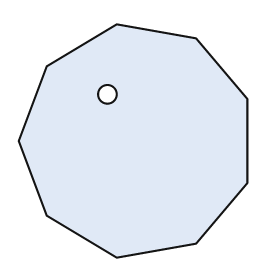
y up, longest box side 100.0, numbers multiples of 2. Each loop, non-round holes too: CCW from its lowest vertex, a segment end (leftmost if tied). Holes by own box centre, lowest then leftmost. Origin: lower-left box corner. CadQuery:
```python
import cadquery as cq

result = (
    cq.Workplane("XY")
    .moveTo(42.0, 0.0)
    .lineTo(76.0, 6.0)
    .lineTo(98.0, 32.0)
    .lineTo(98.0, 68.0)
    .lineTo(76.0, 94.0)
    .lineTo(42.0, 100.0)
    .lineTo(12.0, 82.0)
    .lineTo(0.0, 50.0)
    .lineTo(12.0, 18.0)
    .close()
    .moveTo(38.0, 70.0)
    .circle(4.0)
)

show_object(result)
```